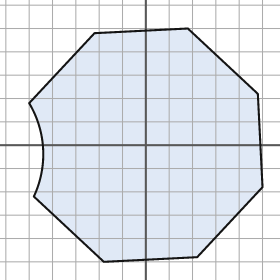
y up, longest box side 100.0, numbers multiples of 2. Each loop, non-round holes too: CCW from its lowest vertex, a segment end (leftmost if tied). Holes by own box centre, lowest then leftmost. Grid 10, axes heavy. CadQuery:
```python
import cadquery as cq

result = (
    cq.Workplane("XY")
    .moveTo(-18.0, -50.0)
    .lineTo(22.0, -48.0)
    .lineTo(50.0, -18.0)
    .lineTo(48.0, 22.0)
    .lineTo(18.0, 50.0)
    .lineTo(-22.0, 48.0)
    .lineTo(-50.0, 18.0)
    .threePointArc((-44.0, -2.0), (-48.0, -22.0))
    .close()
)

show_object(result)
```